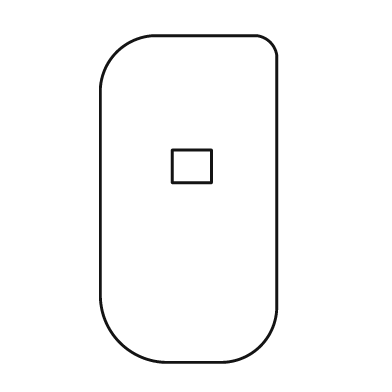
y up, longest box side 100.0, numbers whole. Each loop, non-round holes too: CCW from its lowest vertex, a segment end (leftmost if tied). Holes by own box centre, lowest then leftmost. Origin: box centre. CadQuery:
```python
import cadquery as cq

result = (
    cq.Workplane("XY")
    .moveTo(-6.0, -50.0)
    .lineTo(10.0, -50.0)
    .threePointArc((22.0, -45.0), (27.0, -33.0))
    .lineTo(27.0, 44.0)
    .threePointArc((25.0, 48.0), (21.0, 50.0))
    .lineTo(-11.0, 50.0)
    .threePointArc((-22.0, 45.0), (-27.0, 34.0))
    .lineTo(-27.0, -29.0)
    .threePointArc((-21.0, -44.0), (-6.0, -50.0))
    .close()
    .moveTo(-5.0, 5.0)
    .lineTo(7.0, 5.0)
    .lineTo(7.0, 15.0)
    .lineTo(-5.0, 15.0)
    .close()
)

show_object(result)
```